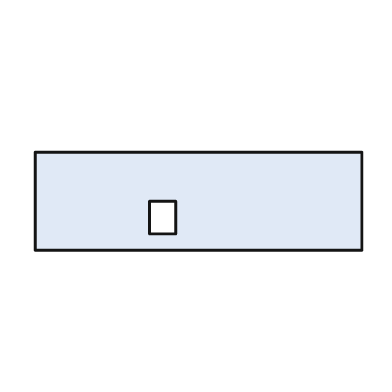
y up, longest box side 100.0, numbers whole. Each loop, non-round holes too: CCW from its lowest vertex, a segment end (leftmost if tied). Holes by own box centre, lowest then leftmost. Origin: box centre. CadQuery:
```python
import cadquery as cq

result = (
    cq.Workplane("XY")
    .moveTo(-50.0, -15.0)
    .lineTo(50.0, -15.0)
    .lineTo(50.0, 15.0)
    .lineTo(-50.0, 15.0)
    .close()
    .moveTo(-15.0, -10.0)
    .lineTo(-7.0, -10.0)
    .lineTo(-7.0, 0.0)
    .lineTo(-15.0, 0.0)
    .close()
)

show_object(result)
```